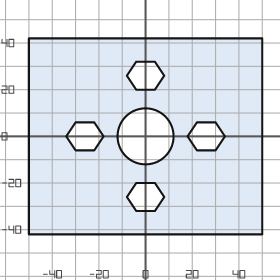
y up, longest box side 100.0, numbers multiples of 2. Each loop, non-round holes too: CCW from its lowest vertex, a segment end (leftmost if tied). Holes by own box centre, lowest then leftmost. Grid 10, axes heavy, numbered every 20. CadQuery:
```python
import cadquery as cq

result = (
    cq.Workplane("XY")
    .moveTo(-50.0, -42.0)
    .lineTo(50.0, -42.0)
    .lineTo(50.0, 42.0)
    .lineTo(-50.0, 42.0)
    .close()
    .moveTo(-4.0, -32.0)
    .lineTo(4.0, -32.0)
    .lineTo(8.0, -26.0)
    .lineTo(4.0, -20.0)
    .lineTo(-4.0, -20.0)
    .lineTo(-8.0, -26.0)
    .close()
    .moveTo(-30.0, -6.0)
    .lineTo(-22.0, -6.0)
    .lineTo(-18.0, 0.0)
    .lineTo(-22.0, 6.0)
    .lineTo(-30.0, 6.0)
    .lineTo(-34.0, 0.0)
    .close()
    .moveTo(0.0, 0.0)
    .circle(12.0)
    .moveTo(22.0, -6.0)
    .lineTo(30.0, -6.0)
    .lineTo(34.0, 0.0)
    .lineTo(30.0, 6.0)
    .lineTo(22.0, 6.0)
    .lineTo(18.0, 0.0)
    .close()
    .moveTo(-4.0, 20.0)
    .lineTo(4.0, 20.0)
    .lineTo(8.0, 26.0)
    .lineTo(4.0, 32.0)
    .lineTo(-4.0, 32.0)
    .lineTo(-8.0, 26.0)
    .close()
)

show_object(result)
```